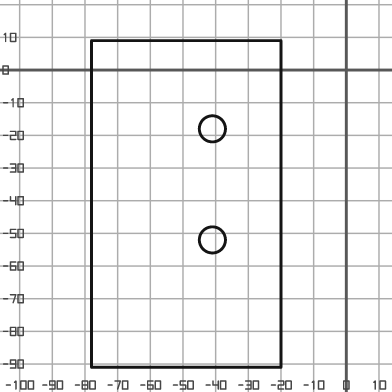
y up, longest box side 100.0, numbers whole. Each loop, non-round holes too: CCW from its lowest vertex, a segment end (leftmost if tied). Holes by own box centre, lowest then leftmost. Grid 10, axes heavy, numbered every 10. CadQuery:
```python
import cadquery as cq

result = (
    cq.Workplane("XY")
    .moveTo(-78.0, -91.0)
    .lineTo(-20.0, -91.0)
    .lineTo(-20.0, 9.0)
    .lineTo(-78.0, 9.0)
    .close()
    .moveTo(-41.0, -52.0)
    .circle(4.0)
    .moveTo(-41.0, -18.0)
    .circle(4.0)
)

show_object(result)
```